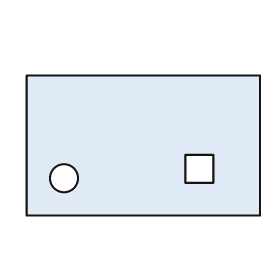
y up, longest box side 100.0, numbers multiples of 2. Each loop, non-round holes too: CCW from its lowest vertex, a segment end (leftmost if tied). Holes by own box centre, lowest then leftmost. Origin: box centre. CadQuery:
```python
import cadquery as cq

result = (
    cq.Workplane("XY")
    .moveTo(-50.0, -30.0)
    .lineTo(50.0, -30.0)
    .lineTo(50.0, 30.0)
    .lineTo(-50.0, 30.0)
    .close()
    .moveTo(-34.0, -14.0)
    .circle(6.0)
    .moveTo(18.0, -16.0)
    .lineTo(30.0, -16.0)
    .lineTo(30.0, -4.0)
    .lineTo(18.0, -4.0)
    .close()
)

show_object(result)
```